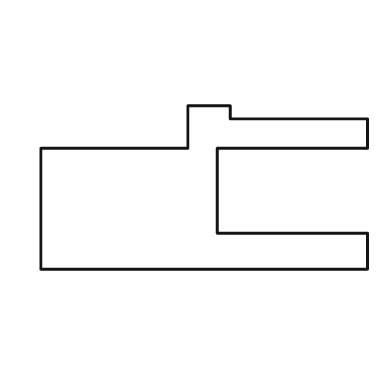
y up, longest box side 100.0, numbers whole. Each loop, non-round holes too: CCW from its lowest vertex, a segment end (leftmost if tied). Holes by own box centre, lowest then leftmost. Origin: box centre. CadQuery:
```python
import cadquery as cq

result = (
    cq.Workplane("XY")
    .moveTo(-50.0, -25.0)
    .lineTo(50.0, -25.0)
    .lineTo(50.0, -14.0)
    .lineTo(4.0, -14.0)
    .lineTo(4.0, 12.0)
    .lineTo(50.0, 12.0)
    .lineTo(50.0, 21.0)
    .lineTo(8.0, 21.0)
    .lineTo(8.0, 25.0)
    .lineTo(-5.0, 25.0)
    .lineTo(-5.0, 12.0)
    .lineTo(-50.0, 12.0)
    .close()
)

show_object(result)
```